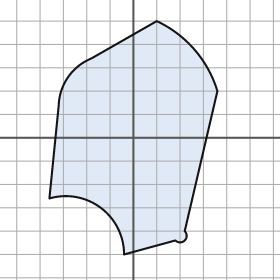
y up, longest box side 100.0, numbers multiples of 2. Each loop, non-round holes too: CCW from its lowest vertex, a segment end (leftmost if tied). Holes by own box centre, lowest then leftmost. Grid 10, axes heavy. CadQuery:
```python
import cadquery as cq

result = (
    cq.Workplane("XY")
    .moveTo(-4.0, -50.0)
    .lineTo(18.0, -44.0)
    .threePointArc((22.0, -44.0), (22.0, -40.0))
    .lineTo(36.0, 20.0)
    .threePointArc((26.0, 38.0), (10.0, 50.0))
    .lineTo(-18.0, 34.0)
    .threePointArc((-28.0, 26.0), (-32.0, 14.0))
    .lineTo(-36.0, -26.0)
    .threePointArc((-14.0, -30.0), (-4.0, -50.0))
    .close()
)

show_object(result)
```